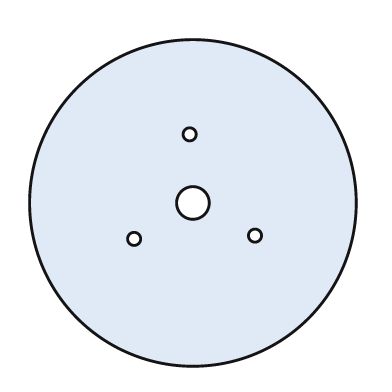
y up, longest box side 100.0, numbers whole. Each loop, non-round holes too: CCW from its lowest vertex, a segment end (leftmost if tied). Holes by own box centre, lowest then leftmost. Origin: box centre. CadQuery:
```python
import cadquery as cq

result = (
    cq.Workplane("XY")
    .moveTo(0.0, 0.0)
    .circle(50.0)
    .moveTo(-18.0, -11.0)
    .circle(2.0)
    .moveTo(19.0, -10.0)
    .circle(2.0)
    .moveTo(0.0, 0.0)
    .circle(5.0)
    .moveTo(-1.0, 21.0)
    .circle(2.0)
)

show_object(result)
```